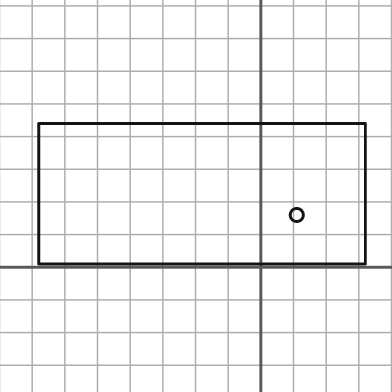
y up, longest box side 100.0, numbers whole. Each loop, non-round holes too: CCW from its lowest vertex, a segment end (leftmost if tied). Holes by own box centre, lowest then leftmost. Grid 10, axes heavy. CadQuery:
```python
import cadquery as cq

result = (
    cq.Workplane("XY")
    .moveTo(-68.0, 1.0)
    .lineTo(32.0, 1.0)
    .lineTo(32.0, 44.0)
    .lineTo(-68.0, 44.0)
    .close()
    .moveTo(11.0, 16.0)
    .circle(2.0)
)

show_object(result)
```